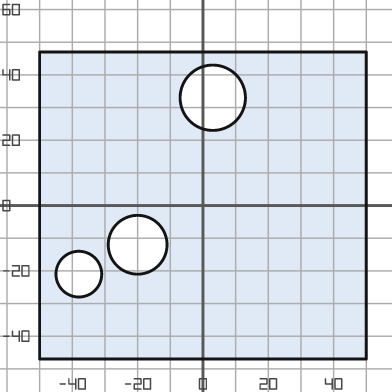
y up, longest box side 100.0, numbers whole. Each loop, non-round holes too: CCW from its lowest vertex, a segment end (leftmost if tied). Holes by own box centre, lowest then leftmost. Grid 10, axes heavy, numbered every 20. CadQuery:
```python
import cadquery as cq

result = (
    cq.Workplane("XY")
    .moveTo(-50.0, -47.0)
    .lineTo(50.0, -47.0)
    .lineTo(50.0, 47.0)
    .lineTo(-50.0, 47.0)
    .close()
    .moveTo(-38.0, -21.0)
    .circle(7.0)
    .moveTo(-20.0, -12.0)
    .circle(9.0)
    .moveTo(3.0, 33.0)
    .circle(10.0)
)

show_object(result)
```